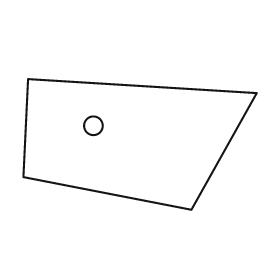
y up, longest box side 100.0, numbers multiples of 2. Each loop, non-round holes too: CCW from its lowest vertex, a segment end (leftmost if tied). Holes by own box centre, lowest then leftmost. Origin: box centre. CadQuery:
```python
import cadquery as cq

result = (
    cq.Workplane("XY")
    .moveTo(22.0, -28.0)
    .lineTo(50.0, 22.0)
    .lineTo(-48.0, 28.0)
    .lineTo(-50.0, -14.0)
    .close()
    .moveTo(-20.0, 8.0)
    .circle(4.0)
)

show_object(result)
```